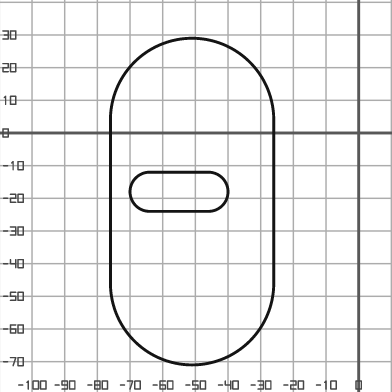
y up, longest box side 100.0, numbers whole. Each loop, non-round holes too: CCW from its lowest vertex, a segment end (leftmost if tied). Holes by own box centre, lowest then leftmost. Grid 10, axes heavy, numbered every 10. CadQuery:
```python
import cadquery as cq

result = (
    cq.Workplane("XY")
    .moveTo(-76.0, -46.0)
    .threePointArc((-51.0, -71.0), (-26.0, -46.0))
    .lineTo(-26.0, 4.0)
    .threePointArc((-51.0, 29.0), (-76.0, 4.0))
    .close()
    .moveTo(-64.0, -24.0)
    .lineTo(-46.0, -24.0)
    .threePointArc((-40.0, -18.0), (-46.0, -12.0))
    .lineTo(-64.0, -12.0)
    .threePointArc((-70.0, -18.0), (-64.0, -24.0))
    .close()
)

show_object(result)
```